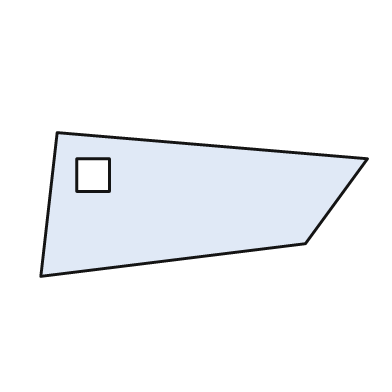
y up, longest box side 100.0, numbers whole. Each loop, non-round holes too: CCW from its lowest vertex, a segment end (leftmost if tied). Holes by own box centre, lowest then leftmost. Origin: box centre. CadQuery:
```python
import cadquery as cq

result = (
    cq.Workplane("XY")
    .moveTo(-50.0, -22.0)
    .lineTo(31.0, -12.0)
    .lineTo(50.0, 14.0)
    .lineTo(-45.0, 22.0)
    .close()
    .moveTo(-39.0, 4.0)
    .lineTo(-29.0, 4.0)
    .lineTo(-29.0, 14.0)
    .lineTo(-39.0, 14.0)
    .close()
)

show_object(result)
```